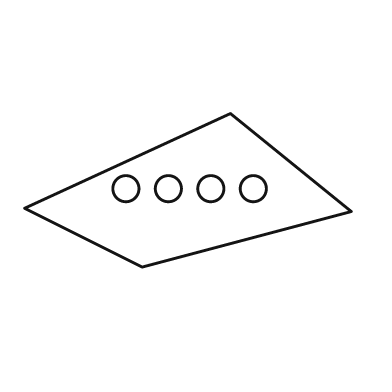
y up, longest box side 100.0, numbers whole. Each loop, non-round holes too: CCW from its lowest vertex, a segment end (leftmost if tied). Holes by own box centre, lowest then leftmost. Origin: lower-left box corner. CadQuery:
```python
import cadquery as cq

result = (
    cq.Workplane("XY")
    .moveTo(36.0, 0.0)
    .lineTo(100.0, 17.0)
    .lineTo(63.0, 47.0)
    .lineTo(0.0, 18.0)
    .close()
    .moveTo(31.0, 24.0)
    .circle(4.0)
    .moveTo(44.0, 24.0)
    .circle(4.0)
    .moveTo(57.0, 24.0)
    .circle(4.0)
    .moveTo(70.0, 24.0)
    .circle(4.0)
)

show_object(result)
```